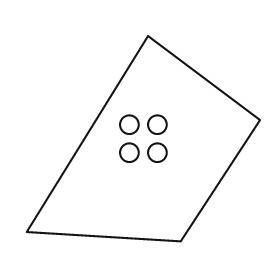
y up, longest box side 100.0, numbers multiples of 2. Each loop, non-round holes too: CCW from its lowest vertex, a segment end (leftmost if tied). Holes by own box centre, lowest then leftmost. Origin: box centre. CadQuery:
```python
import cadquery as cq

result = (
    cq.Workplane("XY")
    .moveTo(16.0, -44.0)
    .lineTo(50.0, 8.0)
    .lineTo(2.0, 44.0)
    .lineTo(-50.0, -40.0)
    .close()
    .moveTo(-6.0, -6.0)
    .circle(4.0)
    .moveTo(6.0, -6.0)
    .circle(4.0)
    .moveTo(-6.0, 6.0)
    .circle(4.0)
    .moveTo(6.0, 6.0)
    .circle(4.0)
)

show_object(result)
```